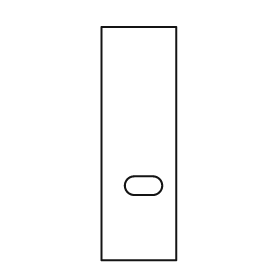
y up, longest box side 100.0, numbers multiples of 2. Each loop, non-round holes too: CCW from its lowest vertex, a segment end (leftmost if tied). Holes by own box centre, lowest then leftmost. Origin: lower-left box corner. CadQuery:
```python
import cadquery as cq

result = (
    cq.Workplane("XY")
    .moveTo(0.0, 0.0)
    .lineTo(32.0, 0.0)
    .lineTo(32.0, 100.0)
    .lineTo(0.0, 100.0)
    .close()
    .moveTo(14.0, 28.0)
    .lineTo(22.0, 28.0)
    .threePointArc((26.0, 32.0), (22.0, 36.0))
    .lineTo(14.0, 36.0)
    .threePointArc((10.0, 32.0), (14.0, 28.0))
    .close()
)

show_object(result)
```